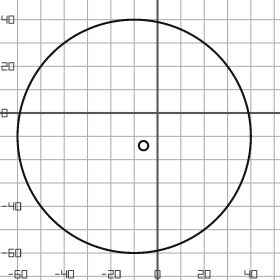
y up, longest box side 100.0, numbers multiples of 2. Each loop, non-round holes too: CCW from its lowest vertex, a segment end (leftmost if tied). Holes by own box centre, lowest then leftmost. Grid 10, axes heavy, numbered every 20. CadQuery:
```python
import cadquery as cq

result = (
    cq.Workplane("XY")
    .moveTo(-10.0, -10.0)
    .circle(50.0)
    .moveTo(-6.0, -14.0)
    .circle(2.0)
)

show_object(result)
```